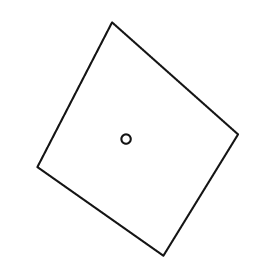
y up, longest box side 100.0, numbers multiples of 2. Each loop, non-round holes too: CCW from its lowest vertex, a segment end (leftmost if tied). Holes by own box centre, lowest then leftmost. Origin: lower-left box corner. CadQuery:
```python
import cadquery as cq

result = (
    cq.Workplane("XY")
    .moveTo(54.0, 0.0)
    .lineTo(86.0, 52.0)
    .lineTo(32.0, 100.0)
    .lineTo(0.0, 38.0)
    .close()
    .moveTo(38.0, 50.0)
    .circle(2.0)
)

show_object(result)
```